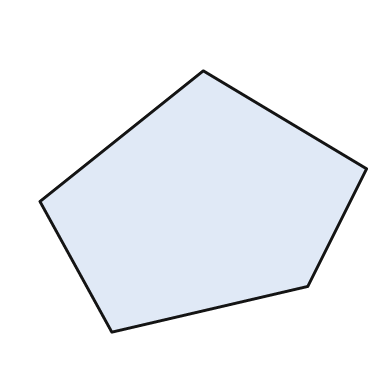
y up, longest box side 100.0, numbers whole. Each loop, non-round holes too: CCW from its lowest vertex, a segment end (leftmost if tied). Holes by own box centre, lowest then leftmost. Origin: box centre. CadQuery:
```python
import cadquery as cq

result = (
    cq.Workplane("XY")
    .moveTo(-28.0, -40.0)
    .lineTo(32.0, -26.0)
    .lineTo(50.0, 10.0)
    .lineTo(0.0, 40.0)
    .lineTo(-50.0, 0.0)
    .close()
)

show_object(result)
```